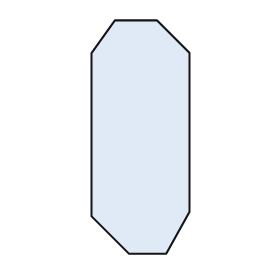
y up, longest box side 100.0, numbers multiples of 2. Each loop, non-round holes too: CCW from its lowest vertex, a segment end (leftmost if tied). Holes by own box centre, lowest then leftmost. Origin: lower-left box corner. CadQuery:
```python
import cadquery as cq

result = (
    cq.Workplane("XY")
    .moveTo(16.0, 0.0)
    .lineTo(32.0, 0.0)
    .lineTo(42.0, 18.0)
    .lineTo(42.0, 86.0)
    .lineTo(28.0, 100.0)
    .lineTo(10.0, 100.0)
    .lineTo(0.0, 86.0)
    .lineTo(0.0, 16.0)
    .close()
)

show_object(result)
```